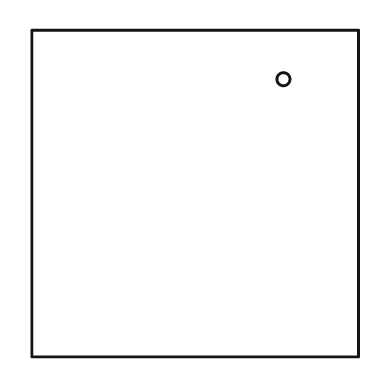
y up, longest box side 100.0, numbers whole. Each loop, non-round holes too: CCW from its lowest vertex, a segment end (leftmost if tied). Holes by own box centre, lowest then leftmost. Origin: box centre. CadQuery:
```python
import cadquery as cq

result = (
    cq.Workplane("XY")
    .moveTo(-50.0, -50.0)
    .lineTo(50.0, -50.0)
    .lineTo(50.0, 50.0)
    .lineTo(-50.0, 50.0)
    .close()
    .moveTo(27.0, 35.0)
    .circle(2.0)
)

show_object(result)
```